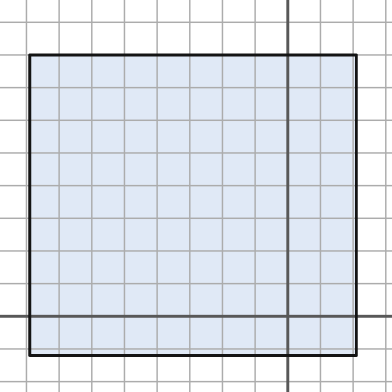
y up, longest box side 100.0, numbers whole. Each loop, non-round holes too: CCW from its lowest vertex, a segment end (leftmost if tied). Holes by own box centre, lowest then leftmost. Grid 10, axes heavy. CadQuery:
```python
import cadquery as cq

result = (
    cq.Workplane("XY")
    .moveTo(-79.0, -12.0)
    .lineTo(21.0, -12.0)
    .lineTo(21.0, 80.0)
    .lineTo(-79.0, 80.0)
    .close()
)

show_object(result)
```